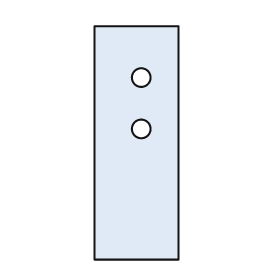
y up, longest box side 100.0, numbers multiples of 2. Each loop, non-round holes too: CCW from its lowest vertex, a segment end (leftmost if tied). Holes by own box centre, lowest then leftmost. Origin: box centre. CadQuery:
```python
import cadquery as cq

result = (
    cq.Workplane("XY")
    .moveTo(-18.0, -50.0)
    .lineTo(18.0, -50.0)
    .lineTo(18.0, 50.0)
    .lineTo(-18.0, 50.0)
    .close()
    .moveTo(2.0, 6.0)
    .circle(4.0)
    .moveTo(2.0, 28.0)
    .circle(4.0)
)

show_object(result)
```